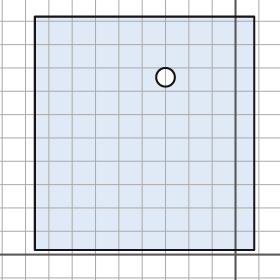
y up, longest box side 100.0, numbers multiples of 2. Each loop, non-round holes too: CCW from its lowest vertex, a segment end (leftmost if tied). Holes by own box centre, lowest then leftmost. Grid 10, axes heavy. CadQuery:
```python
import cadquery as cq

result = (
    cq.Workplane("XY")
    .moveTo(-86.0, 2.0)
    .lineTo(8.0, 2.0)
    .lineTo(8.0, 102.0)
    .lineTo(-86.0, 102.0)
    .close()
    .moveTo(-30.0, 76.0)
    .circle(4.0)
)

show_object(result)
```